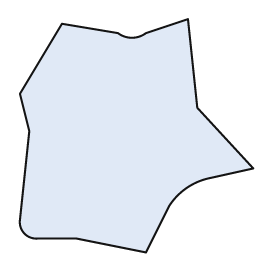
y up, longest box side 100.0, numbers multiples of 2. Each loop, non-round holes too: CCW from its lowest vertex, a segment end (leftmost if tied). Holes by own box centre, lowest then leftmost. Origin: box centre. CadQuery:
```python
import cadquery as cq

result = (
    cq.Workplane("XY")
    .moveTo(4.0, -50.0)
    .lineTo(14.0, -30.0)
    .threePointArc((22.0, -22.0), (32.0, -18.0))
    .lineTo(50.0, -14.0)
    .lineTo(26.0, 12.0)
    .lineTo(22.0, 50.0)
    .lineTo(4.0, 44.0)
    .threePointArc((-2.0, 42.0), (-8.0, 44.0))
    .lineTo(-32.0, 48.0)
    .lineTo(-50.0, 18.0)
    .lineTo(-46.0, 2.0)
    .lineTo(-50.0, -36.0)
    .threePointArc((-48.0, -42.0), (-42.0, -44.0))
    .lineTo(-26.0, -44.0)
    .close()
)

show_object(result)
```